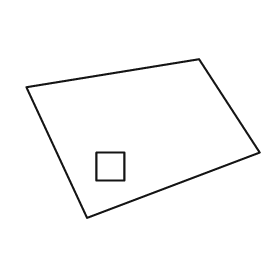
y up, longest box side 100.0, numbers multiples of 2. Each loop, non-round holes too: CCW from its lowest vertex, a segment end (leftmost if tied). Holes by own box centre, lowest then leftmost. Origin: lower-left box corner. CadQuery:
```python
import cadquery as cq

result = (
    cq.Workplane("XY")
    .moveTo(26.0, 0.0)
    .lineTo(100.0, 28.0)
    .lineTo(74.0, 68.0)
    .lineTo(0.0, 56.0)
    .close()
    .moveTo(30.0, 16.0)
    .lineTo(42.0, 16.0)
    .lineTo(42.0, 28.0)
    .lineTo(30.0, 28.0)
    .close()
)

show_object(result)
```